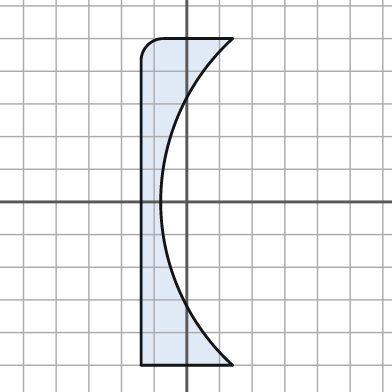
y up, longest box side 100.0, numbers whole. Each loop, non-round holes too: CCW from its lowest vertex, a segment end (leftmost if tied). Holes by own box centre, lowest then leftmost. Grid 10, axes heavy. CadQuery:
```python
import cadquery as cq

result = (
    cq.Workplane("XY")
    .moveTo(-14.0, -50.0)
    .lineTo(14.0, -50.0)
    .threePointArc((-8.0, 0.0), (14.0, 50.0))
    .lineTo(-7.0, 50.0)
    .threePointArc((-12.0, 48.0), (-14.0, 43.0))
    .close()
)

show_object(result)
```